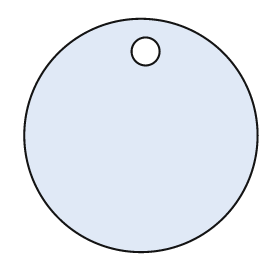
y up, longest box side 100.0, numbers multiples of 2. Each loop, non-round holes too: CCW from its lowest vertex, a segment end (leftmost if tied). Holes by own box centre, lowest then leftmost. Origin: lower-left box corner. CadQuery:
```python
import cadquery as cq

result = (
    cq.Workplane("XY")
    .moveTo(50.0, 50.0)
    .circle(50.0)
    .moveTo(52.0, 86.0)
    .circle(6.0)
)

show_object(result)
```